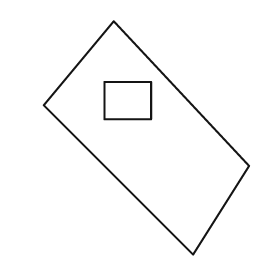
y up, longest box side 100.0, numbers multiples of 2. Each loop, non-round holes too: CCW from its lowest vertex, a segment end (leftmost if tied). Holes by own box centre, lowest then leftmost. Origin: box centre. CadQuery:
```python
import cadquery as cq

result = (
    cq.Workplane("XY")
    .moveTo(20.0, -50.0)
    .lineTo(44.0, -12.0)
    .lineTo(-14.0, 50.0)
    .lineTo(-44.0, 14.0)
    .close()
    .moveTo(-18.0, 8.0)
    .lineTo(2.0, 8.0)
    .lineTo(2.0, 24.0)
    .lineTo(-18.0, 24.0)
    .close()
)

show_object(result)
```